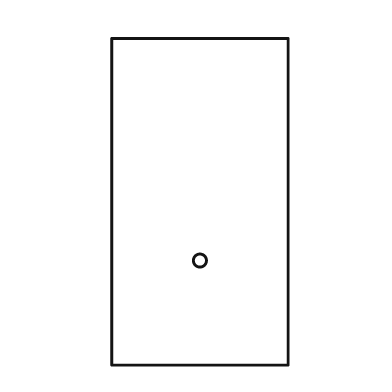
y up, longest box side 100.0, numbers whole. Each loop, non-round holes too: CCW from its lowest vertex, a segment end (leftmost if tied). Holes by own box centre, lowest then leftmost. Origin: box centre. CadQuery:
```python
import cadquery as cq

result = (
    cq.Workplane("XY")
    .moveTo(-27.0, -50.0)
    .lineTo(27.0, -50.0)
    .lineTo(27.0, 50.0)
    .lineTo(-27.0, 50.0)
    .close()
    .moveTo(0.0, -18.0)
    .circle(2.0)
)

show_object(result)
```